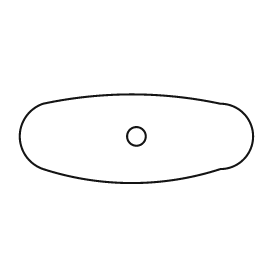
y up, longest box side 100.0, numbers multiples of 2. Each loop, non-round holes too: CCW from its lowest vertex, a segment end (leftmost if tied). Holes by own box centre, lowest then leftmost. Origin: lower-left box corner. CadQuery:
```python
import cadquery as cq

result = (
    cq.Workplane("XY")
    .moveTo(10.0, 6.0)
    .threePointArc((48.0, 0.0), (86.0, 6.0))
    .threePointArc((100.0, 20.0), (86.0, 34.0))
    .threePointArc((48.0, 38.0), (10.0, 34.0))
    .threePointArc((0.0, 20.0), (10.0, 6.0))
    .close()
    .moveTo(50.0, 20.0)
    .circle(4.0)
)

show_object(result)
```